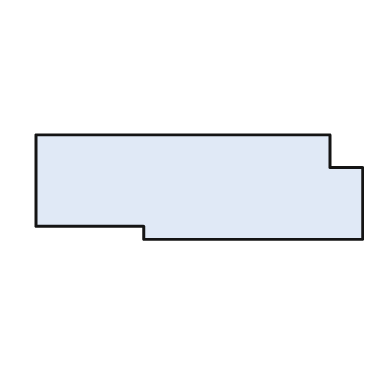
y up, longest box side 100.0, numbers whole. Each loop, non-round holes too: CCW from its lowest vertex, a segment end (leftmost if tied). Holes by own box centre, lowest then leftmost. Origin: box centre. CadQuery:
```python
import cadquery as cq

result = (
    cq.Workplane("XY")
    .moveTo(-17.0, -16.0)
    .lineTo(50.0, -16.0)
    .lineTo(50.0, 6.0)
    .lineTo(40.0, 6.0)
    .lineTo(40.0, 16.0)
    .lineTo(-50.0, 16.0)
    .lineTo(-50.0, -12.0)
    .lineTo(-17.0, -12.0)
    .close()
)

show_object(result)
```